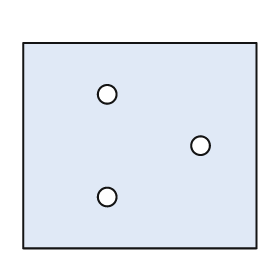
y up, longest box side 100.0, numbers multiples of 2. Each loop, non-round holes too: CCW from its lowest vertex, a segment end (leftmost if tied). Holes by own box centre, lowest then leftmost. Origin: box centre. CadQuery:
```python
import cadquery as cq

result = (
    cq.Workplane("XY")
    .moveTo(-50.0, -44.0)
    .lineTo(50.0, -44.0)
    .lineTo(50.0, 44.0)
    .lineTo(-50.0, 44.0)
    .close()
    .moveTo(-14.0, -22.0)
    .circle(4.0)
    .moveTo(26.0, 0.0)
    .circle(4.0)
    .moveTo(-14.0, 22.0)
    .circle(4.0)
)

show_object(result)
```